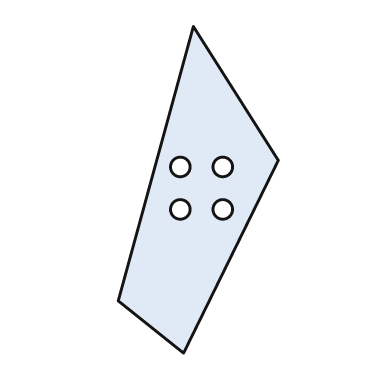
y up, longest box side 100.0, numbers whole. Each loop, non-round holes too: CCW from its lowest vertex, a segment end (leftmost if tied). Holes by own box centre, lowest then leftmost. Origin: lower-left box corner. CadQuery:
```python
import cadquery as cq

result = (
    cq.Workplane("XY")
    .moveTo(20.0, 0.0)
    .lineTo(49.0, 59.0)
    .lineTo(23.0, 100.0)
    .lineTo(0.0, 16.0)
    .close()
    .moveTo(19.0, 44.0)
    .circle(3.0)
    .moveTo(32.0, 44.0)
    .circle(3.0)
    .moveTo(19.0, 57.0)
    .circle(3.0)
    .moveTo(32.0, 57.0)
    .circle(3.0)
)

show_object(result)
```